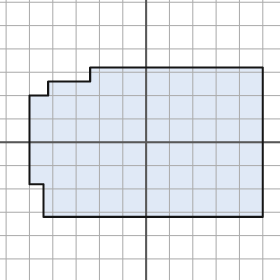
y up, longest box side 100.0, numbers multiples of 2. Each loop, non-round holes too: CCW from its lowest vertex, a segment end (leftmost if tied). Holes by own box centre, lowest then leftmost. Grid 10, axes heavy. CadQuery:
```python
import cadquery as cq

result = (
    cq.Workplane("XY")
    .moveTo(-44.0, -32.0)
    .lineTo(50.0, -32.0)
    .lineTo(50.0, 32.0)
    .lineTo(-24.0, 32.0)
    .lineTo(-24.0, 26.0)
    .lineTo(-42.0, 26.0)
    .lineTo(-42.0, 20.0)
    .lineTo(-50.0, 20.0)
    .lineTo(-50.0, -18.0)
    .lineTo(-44.0, -18.0)
    .close()
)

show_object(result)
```